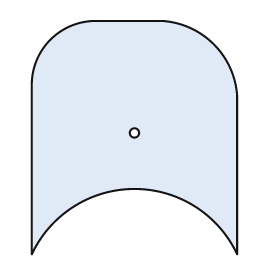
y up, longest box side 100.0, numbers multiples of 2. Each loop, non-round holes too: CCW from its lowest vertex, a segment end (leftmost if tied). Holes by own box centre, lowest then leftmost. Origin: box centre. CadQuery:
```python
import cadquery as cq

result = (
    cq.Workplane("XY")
    .moveTo(-44.0, -50.0)
    .threePointArc((0.0, -22.0), (44.0, -50.0))
    .lineTo(44.0, 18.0)
    .threePointArc((34.0, 40.0), (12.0, 50.0))
    .lineTo(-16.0, 50.0)
    .threePointArc((-36.0, 42.0), (-44.0, 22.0))
    .close()
    .moveTo(0.0, 2.0)
    .circle(2.0)
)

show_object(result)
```